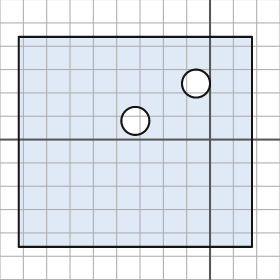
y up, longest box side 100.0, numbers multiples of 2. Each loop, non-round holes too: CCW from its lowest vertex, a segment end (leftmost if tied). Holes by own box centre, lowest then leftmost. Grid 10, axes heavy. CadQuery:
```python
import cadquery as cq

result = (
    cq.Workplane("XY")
    .moveTo(-82.0, -46.0)
    .lineTo(18.0, -46.0)
    .lineTo(18.0, 44.0)
    .lineTo(-82.0, 44.0)
    .close()
    .moveTo(-32.0, 8.0)
    .circle(6.0)
    .moveTo(-6.0, 24.0)
    .circle(6.0)
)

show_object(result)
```